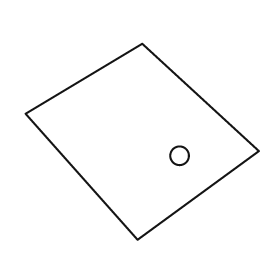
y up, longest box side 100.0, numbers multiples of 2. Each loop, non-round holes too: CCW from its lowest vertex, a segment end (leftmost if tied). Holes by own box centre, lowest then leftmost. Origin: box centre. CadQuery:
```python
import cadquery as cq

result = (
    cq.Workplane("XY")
    .moveTo(-2.0, -42.0)
    .lineTo(50.0, -4.0)
    .lineTo(0.0, 42.0)
    .lineTo(-50.0, 12.0)
    .close()
    .moveTo(16.0, -6.0)
    .circle(4.0)
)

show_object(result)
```